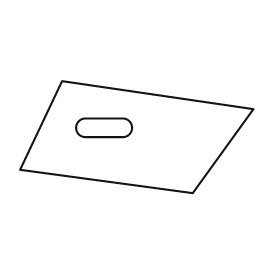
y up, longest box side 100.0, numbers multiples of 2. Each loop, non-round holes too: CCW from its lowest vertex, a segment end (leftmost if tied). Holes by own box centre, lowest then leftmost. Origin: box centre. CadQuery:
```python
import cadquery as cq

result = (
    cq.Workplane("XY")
    .moveTo(24.0, -24.0)
    .lineTo(50.0, 12.0)
    .lineTo(-32.0, 24.0)
    .lineTo(-50.0, -14.0)
    .close()
    .moveTo(-22.0, 0.0)
    .lineTo(-6.0, 0.0)
    .threePointArc((-2.0, 4.0), (-6.0, 8.0))
    .lineTo(-22.0, 8.0)
    .threePointArc((-26.0, 4.0), (-22.0, 0.0))
    .close()
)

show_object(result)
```